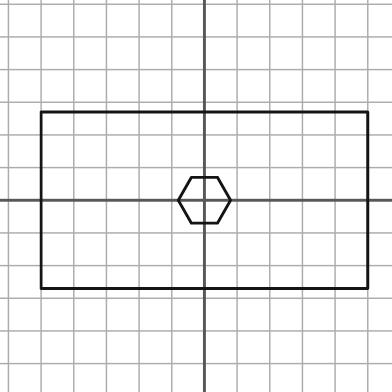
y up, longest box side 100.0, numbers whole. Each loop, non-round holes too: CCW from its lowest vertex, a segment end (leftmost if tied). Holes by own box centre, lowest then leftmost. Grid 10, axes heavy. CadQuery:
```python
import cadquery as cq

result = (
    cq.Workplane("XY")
    .moveTo(-50.0, -27.0)
    .lineTo(50.0, -27.0)
    .lineTo(50.0, 27.0)
    .lineTo(-50.0, 27.0)
    .close()
    .moveTo(-4.0, -7.0)
    .lineTo(4.0, -7.0)
    .lineTo(8.0, 0.0)
    .lineTo(4.0, 7.0)
    .lineTo(-4.0, 7.0)
    .lineTo(-8.0, 0.0)
    .close()
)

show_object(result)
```